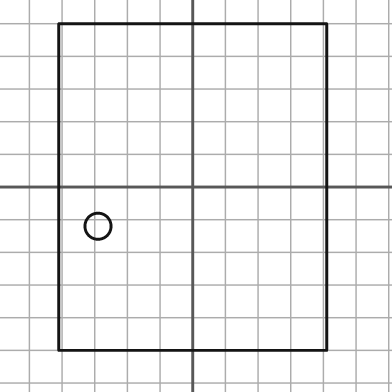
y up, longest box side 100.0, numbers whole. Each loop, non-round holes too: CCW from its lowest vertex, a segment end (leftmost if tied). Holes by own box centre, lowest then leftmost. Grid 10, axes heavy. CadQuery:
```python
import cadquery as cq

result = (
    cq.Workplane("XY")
    .moveTo(-41.0, -50.0)
    .lineTo(41.0, -50.0)
    .lineTo(41.0, 50.0)
    .lineTo(-41.0, 50.0)
    .close()
    .moveTo(-29.0, -12.0)
    .circle(4.0)
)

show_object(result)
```